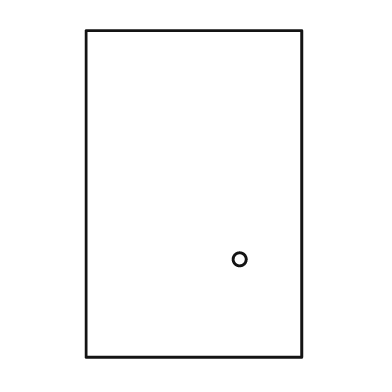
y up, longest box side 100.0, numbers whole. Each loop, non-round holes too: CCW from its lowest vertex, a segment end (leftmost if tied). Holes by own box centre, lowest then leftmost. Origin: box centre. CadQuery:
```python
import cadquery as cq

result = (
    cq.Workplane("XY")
    .moveTo(-33.0, -50.0)
    .lineTo(33.0, -50.0)
    .lineTo(33.0, 50.0)
    .lineTo(-33.0, 50.0)
    .close()
    .moveTo(14.0, -20.0)
    .circle(2.0)
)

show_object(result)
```